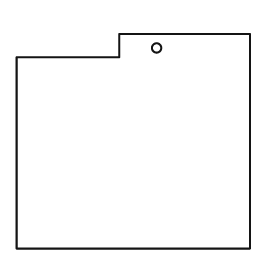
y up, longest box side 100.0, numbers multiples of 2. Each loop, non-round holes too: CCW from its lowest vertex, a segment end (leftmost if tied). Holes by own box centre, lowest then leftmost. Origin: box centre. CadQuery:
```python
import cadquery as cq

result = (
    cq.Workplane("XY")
    .moveTo(-50.0, -46.0)
    .lineTo(50.0, -46.0)
    .lineTo(50.0, 46.0)
    .lineTo(-6.0, 46.0)
    .lineTo(-6.0, 36.0)
    .lineTo(-50.0, 36.0)
    .close()
    .moveTo(10.0, 40.0)
    .circle(2.0)
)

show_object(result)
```